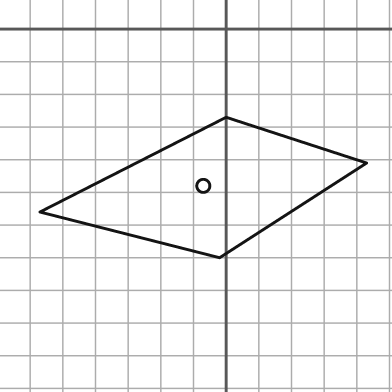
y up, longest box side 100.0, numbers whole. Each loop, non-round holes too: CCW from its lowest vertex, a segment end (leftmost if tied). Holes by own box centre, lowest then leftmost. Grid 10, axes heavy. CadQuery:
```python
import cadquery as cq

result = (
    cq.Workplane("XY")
    .moveTo(-2.0, -70.0)
    .lineTo(43.0, -41.0)
    .lineTo(0.0, -27.0)
    .lineTo(-57.0, -56.0)
    .close()
    .moveTo(-7.0, -48.0)
    .circle(2.0)
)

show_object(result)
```